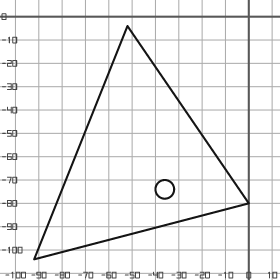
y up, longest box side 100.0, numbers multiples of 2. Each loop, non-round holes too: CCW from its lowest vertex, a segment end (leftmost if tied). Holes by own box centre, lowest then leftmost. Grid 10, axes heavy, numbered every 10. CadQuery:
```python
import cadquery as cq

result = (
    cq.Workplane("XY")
    .moveTo(-92.0, -104.0)
    .lineTo(0.0, -80.0)
    .lineTo(-52.0, -4.0)
    .close()
    .moveTo(-36.0, -74.0)
    .circle(4.0)
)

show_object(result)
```